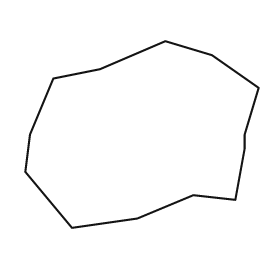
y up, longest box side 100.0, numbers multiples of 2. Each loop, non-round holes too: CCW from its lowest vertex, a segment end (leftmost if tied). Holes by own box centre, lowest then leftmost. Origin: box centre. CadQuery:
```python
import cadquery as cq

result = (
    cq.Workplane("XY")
    .moveTo(-30.0, -40.0)
    .lineTo(-2.0, -36.0)
    .lineTo(22.0, -26.0)
    .lineTo(40.0, -28.0)
    .lineTo(44.0, -6.0)
    .lineTo(44.0, 0.0)
    .lineTo(50.0, 20.0)
    .lineTo(30.0, 34.0)
    .lineTo(10.0, 40.0)
    .lineTo(-18.0, 28.0)
    .lineTo(-38.0, 24.0)
    .lineTo(-48.0, 0.0)
    .lineTo(-50.0, -16.0)
    .close()
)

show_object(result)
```